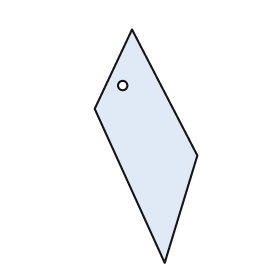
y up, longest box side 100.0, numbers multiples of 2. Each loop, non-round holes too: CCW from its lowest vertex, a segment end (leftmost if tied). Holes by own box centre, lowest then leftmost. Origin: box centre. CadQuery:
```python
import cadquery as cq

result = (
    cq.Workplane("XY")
    .moveTo(8.0, -50.0)
    .lineTo(22.0, -4.0)
    .lineTo(-6.0, 50.0)
    .lineTo(-22.0, 16.0)
    .close()
    .moveTo(-10.0, 26.0)
    .circle(2.0)
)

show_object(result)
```